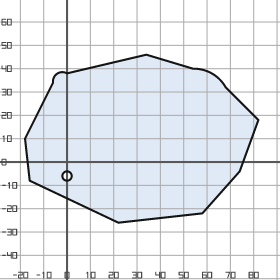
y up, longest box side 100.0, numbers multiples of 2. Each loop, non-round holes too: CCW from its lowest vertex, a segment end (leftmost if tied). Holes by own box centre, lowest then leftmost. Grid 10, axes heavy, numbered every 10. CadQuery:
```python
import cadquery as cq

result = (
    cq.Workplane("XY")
    .moveTo(22.0, -26.0)
    .lineTo(58.0, -22.0)
    .lineTo(74.0, -4.0)
    .lineTo(82.0, 18.0)
    .lineTo(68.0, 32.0)
    .threePointArc((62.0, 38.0), (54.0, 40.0))
    .lineTo(34.0, 46.0)
    .lineTo(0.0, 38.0)
    .threePointArc((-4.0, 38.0), (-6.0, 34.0))
    .lineTo(-18.0, 10.0)
    .lineTo(-16.0, -8.0)
    .close()
    .moveTo(0.0, -6.0)
    .circle(2.0)
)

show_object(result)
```